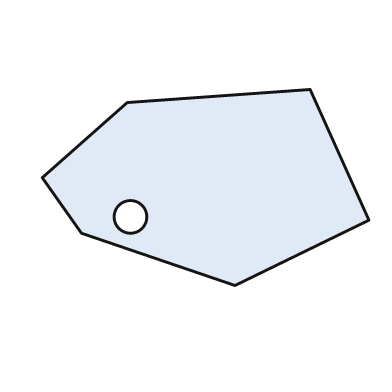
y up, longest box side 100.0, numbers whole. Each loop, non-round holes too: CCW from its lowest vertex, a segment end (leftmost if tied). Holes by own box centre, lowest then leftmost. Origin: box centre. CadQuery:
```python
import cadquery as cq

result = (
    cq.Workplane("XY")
    .moveTo(9.0, -30.0)
    .lineTo(50.0, -10.0)
    .lineTo(32.0, 30.0)
    .lineTo(-24.0, 26.0)
    .lineTo(-50.0, 3.0)
    .lineTo(-38.0, -14.0)
    .close()
    .moveTo(-23.0, -9.0)
    .circle(5.0)
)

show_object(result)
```